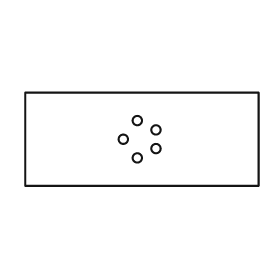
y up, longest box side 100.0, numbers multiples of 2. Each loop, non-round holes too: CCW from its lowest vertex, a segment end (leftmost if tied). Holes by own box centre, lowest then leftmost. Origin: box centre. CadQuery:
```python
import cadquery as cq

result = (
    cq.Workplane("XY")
    .moveTo(-50.0, -20.0)
    .lineTo(50.0, -20.0)
    .lineTo(50.0, 20.0)
    .lineTo(-50.0, 20.0)
    .close()
    .moveTo(-2.0, -8.0)
    .circle(2.0)
    .moveTo(6.0, -4.0)
    .circle(2.0)
    .moveTo(-8.0, 0.0)
    .circle(2.0)
    .moveTo(6.0, 4.0)
    .circle(2.0)
    .moveTo(-2.0, 8.0)
    .circle(2.0)
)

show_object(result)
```